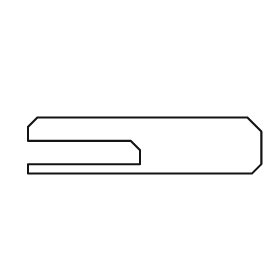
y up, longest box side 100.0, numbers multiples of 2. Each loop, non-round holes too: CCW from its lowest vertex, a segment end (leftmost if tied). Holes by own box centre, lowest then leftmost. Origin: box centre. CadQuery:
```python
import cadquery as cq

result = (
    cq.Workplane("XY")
    .moveTo(-50.0, -12.0)
    .lineTo(46.0, -12.0)
    .lineTo(50.0, -8.0)
    .lineTo(50.0, 6.0)
    .lineTo(44.0, 12.0)
    .lineTo(-46.0, 12.0)
    .lineTo(-50.0, 8.0)
    .lineTo(-50.0, 2.0)
    .lineTo(-6.0, 2.0)
    .lineTo(-2.0, -2.0)
    .lineTo(-2.0, -8.0)
    .lineTo(-50.0, -8.0)
    .close()
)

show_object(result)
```